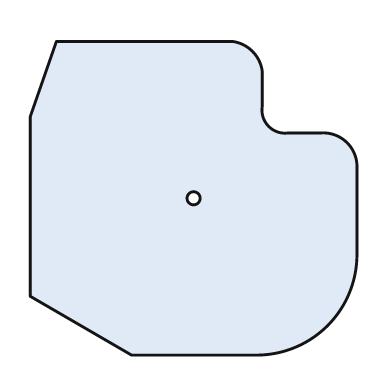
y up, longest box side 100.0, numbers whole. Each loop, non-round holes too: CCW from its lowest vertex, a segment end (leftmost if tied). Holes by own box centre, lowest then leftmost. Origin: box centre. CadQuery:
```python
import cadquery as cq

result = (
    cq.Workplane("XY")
    .moveTo(-19.0, -48.0)
    .lineTo(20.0, -48.0)
    .threePointArc((41.0, -39.0), (50.0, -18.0))
    .lineTo(50.0, 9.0)
    .threePointArc((47.0, 17.0), (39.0, 20.0))
    .lineTo(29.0, 20.0)
    .threePointArc((23.0, 22.0), (21.0, 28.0))
    .lineTo(21.0, 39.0)
    .threePointArc((18.0, 45.0), (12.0, 48.0))
    .lineTo(-42.0, 48.0)
    .lineTo(-50.0, 25.0)
    .lineTo(-50.0, -30.0)
    .close()
    .moveTo(0.0, 0.0)
    .circle(2.0)
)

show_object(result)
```